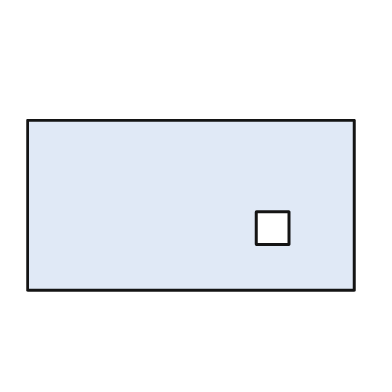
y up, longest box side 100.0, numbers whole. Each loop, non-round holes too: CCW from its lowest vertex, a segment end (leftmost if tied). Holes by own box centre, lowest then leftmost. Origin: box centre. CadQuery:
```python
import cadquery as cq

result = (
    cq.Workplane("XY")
    .moveTo(-50.0, -26.0)
    .lineTo(50.0, -26.0)
    .lineTo(50.0, 26.0)
    .lineTo(-50.0, 26.0)
    .close()
    .moveTo(20.0, -12.0)
    .lineTo(30.0, -12.0)
    .lineTo(30.0, -2.0)
    .lineTo(20.0, -2.0)
    .close()
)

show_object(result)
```